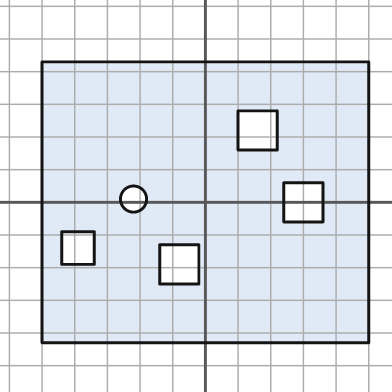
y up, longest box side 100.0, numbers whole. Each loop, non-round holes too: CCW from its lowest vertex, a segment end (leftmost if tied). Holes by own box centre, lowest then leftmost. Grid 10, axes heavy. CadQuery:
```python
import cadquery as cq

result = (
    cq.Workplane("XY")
    .moveTo(-50.0, -43.0)
    .lineTo(50.0, -43.0)
    .lineTo(50.0, 43.0)
    .lineTo(-50.0, 43.0)
    .close()
    .moveTo(-14.0, -25.0)
    .lineTo(-2.0, -25.0)
    .lineTo(-2.0, -13.0)
    .lineTo(-14.0, -13.0)
    .close()
    .moveTo(-44.0, -19.0)
    .lineTo(-34.0, -19.0)
    .lineTo(-34.0, -9.0)
    .lineTo(-44.0, -9.0)
    .close()
    .moveTo(24.0, -6.0)
    .lineTo(36.0, -6.0)
    .lineTo(36.0, 6.0)
    .lineTo(24.0, 6.0)
    .close()
    .moveTo(-22.0, 1.0)
    .circle(4.0)
    .moveTo(10.0, 16.0)
    .lineTo(22.0, 16.0)
    .lineTo(22.0, 28.0)
    .lineTo(10.0, 28.0)
    .close()
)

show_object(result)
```